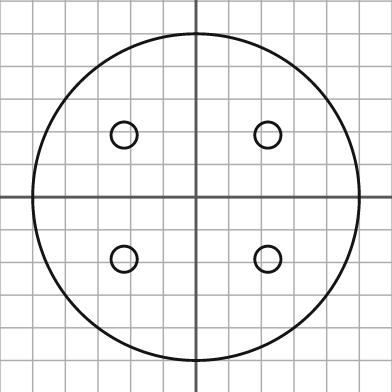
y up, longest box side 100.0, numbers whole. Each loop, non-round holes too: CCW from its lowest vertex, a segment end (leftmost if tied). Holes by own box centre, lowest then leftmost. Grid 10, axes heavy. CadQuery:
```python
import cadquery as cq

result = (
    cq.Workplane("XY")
    .moveTo(0.0, 0.0)
    .circle(50.0)
    .moveTo(-22.0, -19.0)
    .circle(4.0)
    .moveTo(22.0, -19.0)
    .circle(4.0)
    .moveTo(-22.0, 19.0)
    .circle(4.0)
    .moveTo(22.0, 19.0)
    .circle(4.0)
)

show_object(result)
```